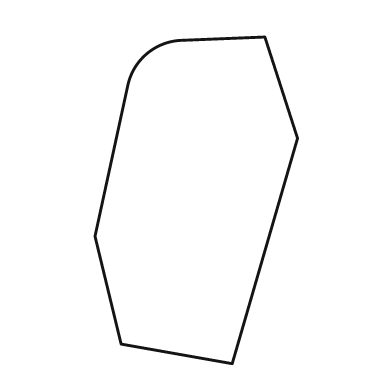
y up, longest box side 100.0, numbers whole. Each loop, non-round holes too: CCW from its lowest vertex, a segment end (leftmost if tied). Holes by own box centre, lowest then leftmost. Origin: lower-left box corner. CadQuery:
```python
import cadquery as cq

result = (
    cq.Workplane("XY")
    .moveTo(42.0, 0.0)
    .lineTo(62.0, 69.0)
    .lineTo(52.0, 100.0)
    .lineTo(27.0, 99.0)
    .threePointArc((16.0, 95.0), (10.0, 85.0))
    .lineTo(0.0, 39.0)
    .lineTo(8.0, 6.0)
    .close()
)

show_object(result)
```